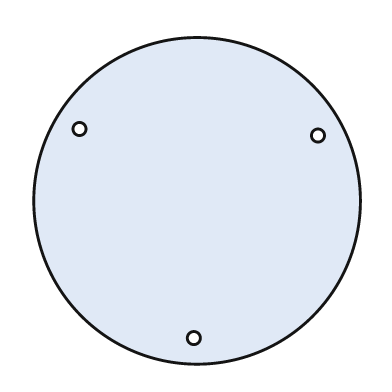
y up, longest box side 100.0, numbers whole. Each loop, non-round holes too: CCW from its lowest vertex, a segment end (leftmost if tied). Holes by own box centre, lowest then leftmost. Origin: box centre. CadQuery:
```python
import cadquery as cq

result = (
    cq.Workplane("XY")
    .moveTo(0.0, 0.0)
    .circle(50.0)
    .moveTo(-1.0, -42.0)
    .circle(2.0)
    .moveTo(37.0, 20.0)
    .circle(2.0)
    .moveTo(-36.0, 22.0)
    .circle(2.0)
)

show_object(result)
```